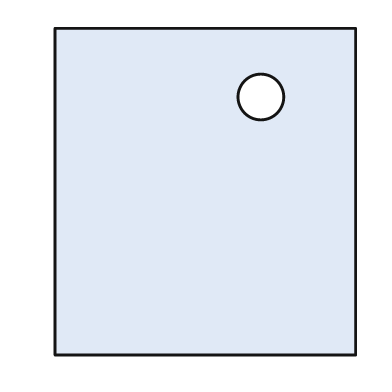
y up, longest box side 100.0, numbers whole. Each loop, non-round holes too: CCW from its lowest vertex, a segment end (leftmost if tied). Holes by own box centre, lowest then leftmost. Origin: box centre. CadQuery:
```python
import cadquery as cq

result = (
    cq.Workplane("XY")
    .moveTo(-46.0, -50.0)
    .lineTo(46.0, -50.0)
    .lineTo(46.0, 50.0)
    .lineTo(-46.0, 50.0)
    .close()
    .moveTo(17.0, 29.0)
    .circle(7.0)
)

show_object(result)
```